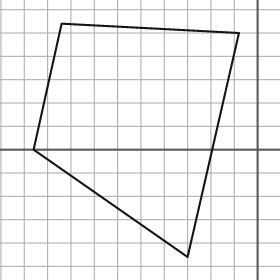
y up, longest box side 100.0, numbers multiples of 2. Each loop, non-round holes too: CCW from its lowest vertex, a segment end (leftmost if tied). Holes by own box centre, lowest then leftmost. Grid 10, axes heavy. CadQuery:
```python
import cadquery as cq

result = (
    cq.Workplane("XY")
    .moveTo(-30.0, -46.0)
    .lineTo(-8.0, 50.0)
    .lineTo(-84.0, 54.0)
    .lineTo(-96.0, 0.0)
    .close()
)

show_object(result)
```